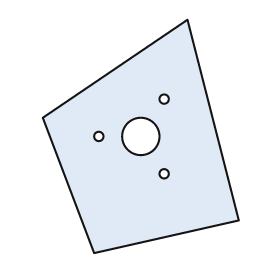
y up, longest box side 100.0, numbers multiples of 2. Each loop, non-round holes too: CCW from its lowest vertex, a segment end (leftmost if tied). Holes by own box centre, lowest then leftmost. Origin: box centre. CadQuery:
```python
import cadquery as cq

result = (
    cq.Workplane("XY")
    .moveTo(-20.0, -50.0)
    .lineTo(42.0, -36.0)
    .lineTo(20.0, 50.0)
    .lineTo(-42.0, 8.0)
    .close()
    .moveTo(10.0, -16.0)
    .circle(2.0)
    .moveTo(-18.0, 0.0)
    .circle(2.0)
    .moveTo(0.0, 0.0)
    .circle(8.0)
    .moveTo(10.0, 16.0)
    .circle(2.0)
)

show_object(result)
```